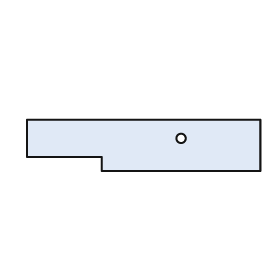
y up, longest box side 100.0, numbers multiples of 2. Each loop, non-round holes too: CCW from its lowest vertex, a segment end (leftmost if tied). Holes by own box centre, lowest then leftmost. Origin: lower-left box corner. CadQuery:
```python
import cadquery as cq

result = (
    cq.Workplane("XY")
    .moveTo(32.0, 0.0)
    .lineTo(100.0, 0.0)
    .lineTo(100.0, 22.0)
    .lineTo(0.0, 22.0)
    .lineTo(0.0, 6.0)
    .lineTo(32.0, 6.0)
    .close()
    .moveTo(66.0, 14.0)
    .circle(2.0)
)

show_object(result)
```